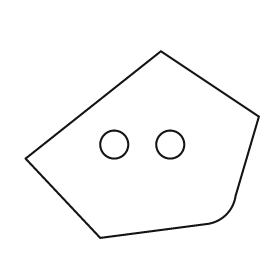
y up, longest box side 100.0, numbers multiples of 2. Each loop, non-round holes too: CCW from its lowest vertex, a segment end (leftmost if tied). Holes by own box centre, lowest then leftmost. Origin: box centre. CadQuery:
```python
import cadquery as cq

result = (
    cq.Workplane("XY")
    .moveTo(-18.0, -40.0)
    .lineTo(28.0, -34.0)
    .threePointArc((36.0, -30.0), (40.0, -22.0))
    .lineTo(50.0, 12.0)
    .lineTo(8.0, 40.0)
    .lineTo(-50.0, -6.0)
    .close()
    .moveTo(-12.0, 0.0)
    .circle(6.0)
    .moveTo(12.0, 0.0)
    .circle(6.0)
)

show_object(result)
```